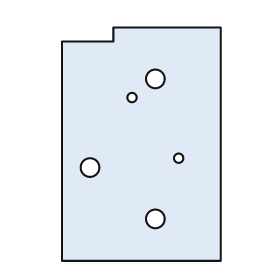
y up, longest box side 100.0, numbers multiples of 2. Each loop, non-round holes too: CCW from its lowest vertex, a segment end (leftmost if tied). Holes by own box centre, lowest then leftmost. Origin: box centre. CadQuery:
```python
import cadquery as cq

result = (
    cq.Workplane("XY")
    .moveTo(-34.0, -50.0)
    .lineTo(34.0, -50.0)
    .lineTo(34.0, 50.0)
    .lineTo(-12.0, 50.0)
    .lineTo(-12.0, 44.0)
    .lineTo(-34.0, 44.0)
    .close()
    .moveTo(6.0, -32.0)
    .circle(4.0)
    .moveTo(-22.0, -10.0)
    .circle(4.0)
    .moveTo(16.0, -6.0)
    .circle(2.0)
    .moveTo(-4.0, 20.0)
    .circle(2.0)
    .moveTo(6.0, 28.0)
    .circle(4.0)
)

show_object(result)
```